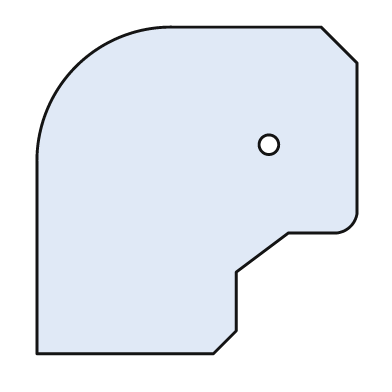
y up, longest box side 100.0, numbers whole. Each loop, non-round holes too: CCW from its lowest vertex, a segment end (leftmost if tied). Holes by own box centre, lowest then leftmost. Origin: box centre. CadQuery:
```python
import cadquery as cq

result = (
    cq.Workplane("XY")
    .moveTo(-49.0, -50.0)
    .lineTo(5.0, -50.0)
    .lineTo(12.0, -43.0)
    .lineTo(12.0, -25.0)
    .lineTo(28.0, -13.0)
    .lineTo(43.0, -13.0)
    .threePointArc((47.0, -11.0), (49.0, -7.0))
    .lineTo(49.0, 39.0)
    .lineTo(38.0, 50.0)
    .lineTo(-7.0, 50.0)
    .threePointArc((-37.0, 38.0), (-49.0, 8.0))
    .close()
    .moveTo(22.0, 14.0)
    .circle(3.0)
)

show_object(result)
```